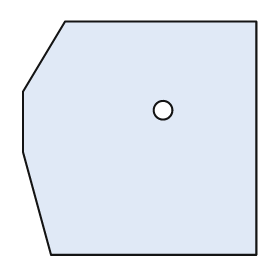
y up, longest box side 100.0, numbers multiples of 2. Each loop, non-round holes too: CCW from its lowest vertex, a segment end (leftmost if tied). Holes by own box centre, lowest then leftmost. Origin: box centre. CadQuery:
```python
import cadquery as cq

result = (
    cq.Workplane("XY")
    .moveTo(-38.0, -50.0)
    .lineTo(50.0, -50.0)
    .lineTo(50.0, 50.0)
    .lineTo(-32.0, 50.0)
    .lineTo(-50.0, 20.0)
    .lineTo(-50.0, -6.0)
    .close()
    .moveTo(10.0, 12.0)
    .circle(4.0)
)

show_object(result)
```